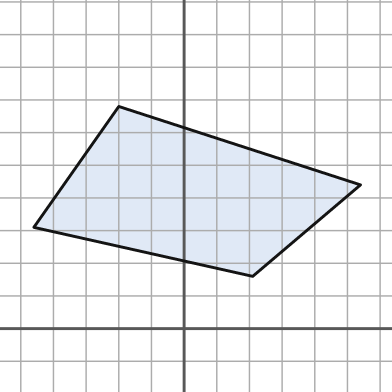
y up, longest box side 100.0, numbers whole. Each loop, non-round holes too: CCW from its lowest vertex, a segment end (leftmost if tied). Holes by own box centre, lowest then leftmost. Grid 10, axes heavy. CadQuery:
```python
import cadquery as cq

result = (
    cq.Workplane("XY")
    .moveTo(21.0, 16.0)
    .lineTo(54.0, 44.0)
    .lineTo(-20.0, 68.0)
    .lineTo(-46.0, 31.0)
    .close()
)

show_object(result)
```